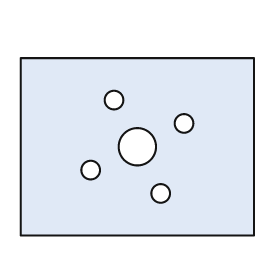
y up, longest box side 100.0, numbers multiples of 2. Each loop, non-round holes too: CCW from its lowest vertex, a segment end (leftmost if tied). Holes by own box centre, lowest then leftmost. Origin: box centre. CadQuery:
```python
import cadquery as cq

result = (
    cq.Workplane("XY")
    .moveTo(-50.0, -38.0)
    .lineTo(50.0, -38.0)
    .lineTo(50.0, 38.0)
    .lineTo(-50.0, 38.0)
    .close()
    .moveTo(10.0, -20.0)
    .circle(4.0)
    .moveTo(-20.0, -10.0)
    .circle(4.0)
    .moveTo(0.0, 0.0)
    .circle(8.0)
    .moveTo(20.0, 10.0)
    .circle(4.0)
    .moveTo(-10.0, 20.0)
    .circle(4.0)
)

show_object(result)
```